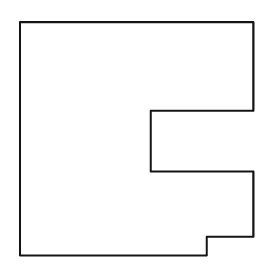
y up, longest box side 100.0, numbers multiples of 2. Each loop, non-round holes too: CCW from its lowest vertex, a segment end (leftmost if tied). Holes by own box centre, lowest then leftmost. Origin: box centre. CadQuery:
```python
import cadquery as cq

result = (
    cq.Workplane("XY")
    .moveTo(-50.0, -50.0)
    .lineTo(30.0, -50.0)
    .lineTo(30.0, -42.0)
    .lineTo(50.0, -42.0)
    .lineTo(50.0, -14.0)
    .lineTo(6.0, -14.0)
    .lineTo(6.0, 12.0)
    .lineTo(50.0, 12.0)
    .lineTo(50.0, 50.0)
    .lineTo(-50.0, 50.0)
    .close()
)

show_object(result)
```